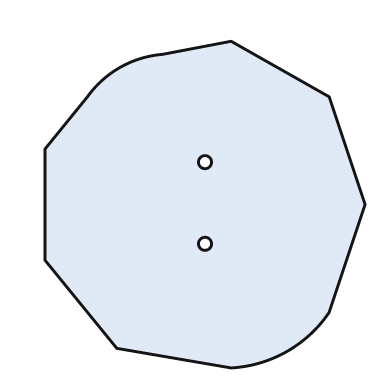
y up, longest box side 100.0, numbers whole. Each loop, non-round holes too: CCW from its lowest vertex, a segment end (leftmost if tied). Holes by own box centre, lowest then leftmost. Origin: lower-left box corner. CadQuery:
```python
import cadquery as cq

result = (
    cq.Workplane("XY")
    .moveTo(57.0, 0.0)
    .threePointArc((74.0, 5.0), (87.0, 17.0))
    .lineTo(98.0, 50.0)
    .lineTo(87.0, 83.0)
    .lineTo(57.0, 100.0)
    .lineTo(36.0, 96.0)
    .threePointArc((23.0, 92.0), (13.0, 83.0))
    .lineTo(0.0, 67.0)
    .lineTo(0.0, 33.0)
    .lineTo(22.0, 6.0)
    .close()
    .moveTo(49.0, 38.0)
    .circle(2.0)
    .moveTo(49.0, 63.0)
    .circle(2.0)
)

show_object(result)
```